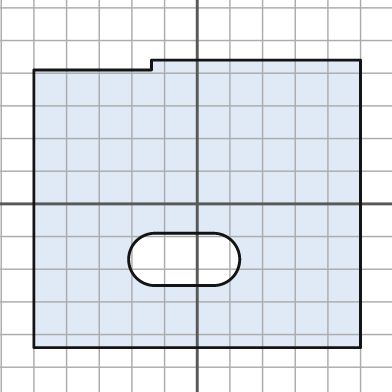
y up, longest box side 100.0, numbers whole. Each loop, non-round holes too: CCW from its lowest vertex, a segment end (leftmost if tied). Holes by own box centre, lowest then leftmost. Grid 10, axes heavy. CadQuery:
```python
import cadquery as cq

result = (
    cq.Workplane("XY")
    .moveTo(-50.0, -44.0)
    .lineTo(50.0, -44.0)
    .lineTo(50.0, 44.0)
    .lineTo(-14.0, 44.0)
    .lineTo(-14.0, 41.0)
    .lineTo(-50.0, 41.0)
    .close()
    .moveTo(-13.0, -25.0)
    .lineTo(5.0, -25.0)
    .threePointArc((13.0, -17.0), (5.0, -9.0))
    .lineTo(-13.0, -9.0)
    .threePointArc((-21.0, -17.0), (-13.0, -25.0))
    .close()
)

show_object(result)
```